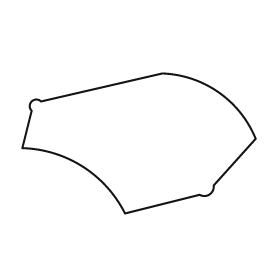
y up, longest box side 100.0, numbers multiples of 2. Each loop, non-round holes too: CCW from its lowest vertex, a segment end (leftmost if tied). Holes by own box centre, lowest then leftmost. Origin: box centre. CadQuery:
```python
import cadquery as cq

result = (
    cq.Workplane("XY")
    .moveTo(-6.0, -30.0)
    .lineTo(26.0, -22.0)
    .threePointArc((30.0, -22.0), (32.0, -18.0))
    .lineTo(50.0, 2.0)
    .threePointArc((34.0, 22.0), (10.0, 30.0))
    .lineTo(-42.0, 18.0)
    .threePointArc((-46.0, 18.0), (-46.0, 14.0))
    .lineTo(-50.0, -2.0)
    .threePointArc((-24.0, -10.0), (-6.0, -30.0))
    .close()
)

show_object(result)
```